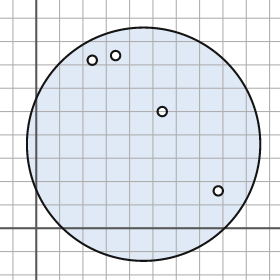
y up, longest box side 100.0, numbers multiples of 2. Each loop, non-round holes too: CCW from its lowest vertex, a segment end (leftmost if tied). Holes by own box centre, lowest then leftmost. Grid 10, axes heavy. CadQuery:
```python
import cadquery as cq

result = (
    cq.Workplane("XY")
    .moveTo(46.0, 36.0)
    .circle(50.0)
    .moveTo(78.0, 16.0)
    .circle(2.0)
    .moveTo(54.0, 50.0)
    .circle(2.0)
    .moveTo(24.0, 72.0)
    .circle(2.0)
    .moveTo(34.0, 74.0)
    .circle(2.0)
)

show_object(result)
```